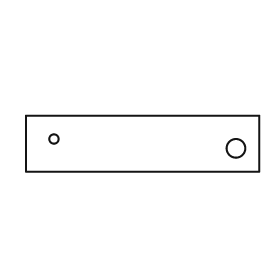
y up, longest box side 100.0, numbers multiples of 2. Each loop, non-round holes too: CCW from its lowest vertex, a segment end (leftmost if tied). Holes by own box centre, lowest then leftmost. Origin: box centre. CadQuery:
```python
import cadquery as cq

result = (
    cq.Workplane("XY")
    .moveTo(-50.0, -12.0)
    .lineTo(50.0, -12.0)
    .lineTo(50.0, 12.0)
    .lineTo(-50.0, 12.0)
    .close()
    .moveTo(40.0, -2.0)
    .circle(4.0)
    .moveTo(-38.0, 2.0)
    .circle(2.0)
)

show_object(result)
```